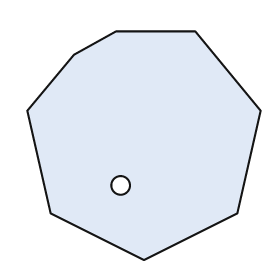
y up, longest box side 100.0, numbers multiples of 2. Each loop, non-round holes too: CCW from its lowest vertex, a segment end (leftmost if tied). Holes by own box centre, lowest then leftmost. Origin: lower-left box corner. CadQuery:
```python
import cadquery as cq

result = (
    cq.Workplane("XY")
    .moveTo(50.0, 0.0)
    .lineTo(90.0, 20.0)
    .lineTo(100.0, 64.0)
    .lineTo(72.0, 98.0)
    .lineTo(38.0, 98.0)
    .lineTo(20.0, 88.0)
    .lineTo(0.0, 64.0)
    .lineTo(10.0, 20.0)
    .close()
    .moveTo(40.0, 32.0)
    .circle(4.0)
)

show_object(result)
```